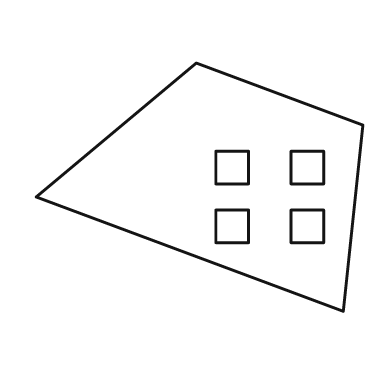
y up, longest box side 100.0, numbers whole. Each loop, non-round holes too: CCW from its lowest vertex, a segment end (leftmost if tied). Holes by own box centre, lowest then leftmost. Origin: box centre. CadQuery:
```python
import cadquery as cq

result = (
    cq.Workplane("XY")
    .moveTo(44.0, -38.0)
    .lineTo(50.0, 19.0)
    .lineTo(-1.0, 38.0)
    .lineTo(-50.0, -3.0)
    .close()
    .moveTo(5.0, -17.0)
    .lineTo(15.0, -17.0)
    .lineTo(15.0, -7.0)
    .lineTo(5.0, -7.0)
    .close()
    .moveTo(28.0, -17.0)
    .lineTo(38.0, -17.0)
    .lineTo(38.0, -7.0)
    .lineTo(28.0, -7.0)
    .close()
    .moveTo(5.0, 1.0)
    .lineTo(15.0, 1.0)
    .lineTo(15.0, 11.0)
    .lineTo(5.0, 11.0)
    .close()
    .moveTo(28.0, 1.0)
    .lineTo(38.0, 1.0)
    .lineTo(38.0, 11.0)
    .lineTo(28.0, 11.0)
    .close()
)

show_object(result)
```